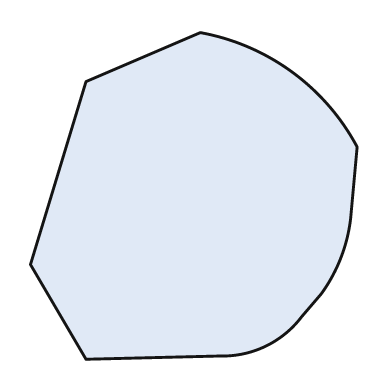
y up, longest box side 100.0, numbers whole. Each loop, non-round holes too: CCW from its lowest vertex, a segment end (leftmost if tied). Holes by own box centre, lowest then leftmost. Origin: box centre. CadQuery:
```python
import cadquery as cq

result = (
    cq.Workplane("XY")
    .moveTo(-33.0, -50.0)
    .lineTo(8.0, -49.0)
    .threePointArc((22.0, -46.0), (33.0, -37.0))
    .lineTo(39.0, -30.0)
    .threePointArc((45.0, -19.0), (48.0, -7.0))
    .lineTo(50.0, 15.0)
    .threePointArc((30.0, 38.0), (2.0, 50.0))
    .lineTo(-33.0, 35.0)
    .lineTo(-50.0, -21.0)
    .close()
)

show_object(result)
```